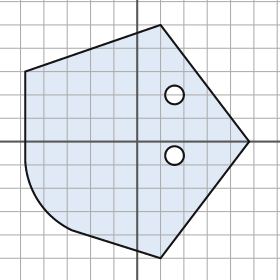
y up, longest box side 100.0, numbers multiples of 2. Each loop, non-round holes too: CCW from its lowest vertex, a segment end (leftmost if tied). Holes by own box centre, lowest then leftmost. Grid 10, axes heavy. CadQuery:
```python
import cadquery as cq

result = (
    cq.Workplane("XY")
    .moveTo(10.0, -50.0)
    .lineTo(48.0, 0.0)
    .lineTo(10.0, 50.0)
    .lineTo(-48.0, 30.0)
    .lineTo(-48.0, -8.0)
    .threePointArc((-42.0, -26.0), (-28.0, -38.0))
    .close()
    .moveTo(16.0, -6.0)
    .circle(4.0)
    .moveTo(16.0, 20.0)
    .circle(4.0)
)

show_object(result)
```